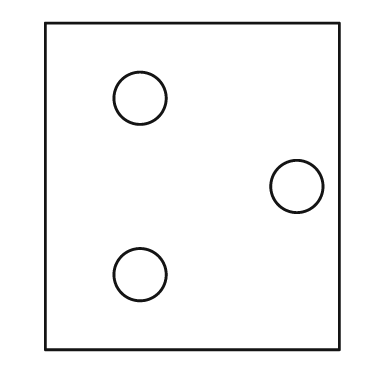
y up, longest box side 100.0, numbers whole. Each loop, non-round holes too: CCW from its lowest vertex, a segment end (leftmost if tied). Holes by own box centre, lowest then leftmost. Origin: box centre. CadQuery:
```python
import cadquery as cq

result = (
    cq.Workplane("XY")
    .moveTo(-45.0, -50.0)
    .lineTo(45.0, -50.0)
    .lineTo(45.0, 50.0)
    .lineTo(-45.0, 50.0)
    .close()
    .moveTo(-16.0, -27.0)
    .circle(8.0)
    .moveTo(32.0, 0.0)
    .circle(8.0)
    .moveTo(-16.0, 27.0)
    .circle(8.0)
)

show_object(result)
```